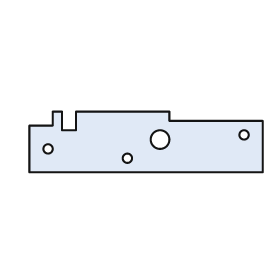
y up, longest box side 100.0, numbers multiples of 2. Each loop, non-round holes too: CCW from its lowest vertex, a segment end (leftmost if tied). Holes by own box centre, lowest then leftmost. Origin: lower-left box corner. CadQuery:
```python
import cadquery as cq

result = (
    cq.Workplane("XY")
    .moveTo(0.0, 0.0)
    .lineTo(100.0, 0.0)
    .lineTo(100.0, 22.0)
    .lineTo(60.0, 22.0)
    .lineTo(60.0, 26.0)
    .lineTo(20.0, 26.0)
    .lineTo(20.0, 18.0)
    .lineTo(14.0, 18.0)
    .lineTo(14.0, 26.0)
    .lineTo(10.0, 26.0)
    .lineTo(10.0, 20.0)
    .lineTo(0.0, 20.0)
    .close()
    .moveTo(42.0, 6.0)
    .circle(2.0)
    .moveTo(8.0, 10.0)
    .circle(2.0)
    .moveTo(56.0, 14.0)
    .circle(4.0)
    .moveTo(92.0, 16.0)
    .circle(2.0)
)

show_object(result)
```